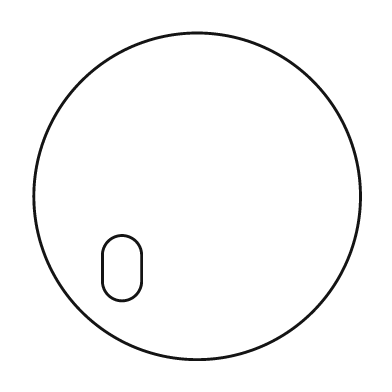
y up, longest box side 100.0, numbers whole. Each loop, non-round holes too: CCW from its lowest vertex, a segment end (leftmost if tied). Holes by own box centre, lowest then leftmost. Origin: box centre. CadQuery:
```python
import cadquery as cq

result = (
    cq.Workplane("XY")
    .moveTo(0.0, 0.0)
    .circle(50.0)
    .moveTo(-29.0, -26.0)
    .threePointArc((-23.0, -32.0), (-17.0, -26.0))
    .lineTo(-17.0, -18.0)
    .threePointArc((-23.0, -12.0), (-29.0, -18.0))
    .close()
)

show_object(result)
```